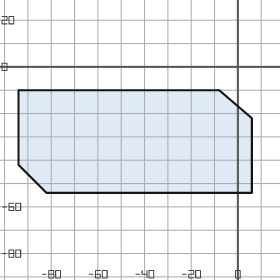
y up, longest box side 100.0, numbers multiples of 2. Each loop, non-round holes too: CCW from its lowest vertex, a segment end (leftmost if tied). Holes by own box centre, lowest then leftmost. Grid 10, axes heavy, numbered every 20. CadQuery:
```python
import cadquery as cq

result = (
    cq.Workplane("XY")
    .moveTo(-82.0, -54.0)
    .lineTo(6.0, -54.0)
    .lineTo(6.0, -22.0)
    .lineTo(-8.0, -10.0)
    .lineTo(-94.0, -10.0)
    .lineTo(-94.0, -42.0)
    .close()
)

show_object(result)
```